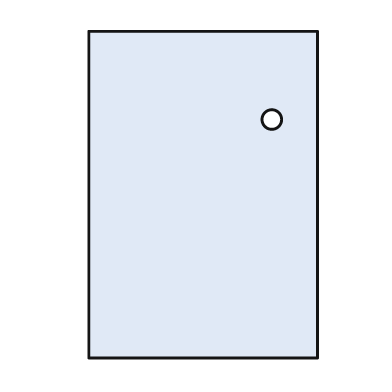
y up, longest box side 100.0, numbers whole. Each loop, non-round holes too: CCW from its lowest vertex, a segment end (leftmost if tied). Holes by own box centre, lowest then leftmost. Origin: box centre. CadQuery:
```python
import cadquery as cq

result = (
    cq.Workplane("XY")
    .moveTo(-35.0, -50.0)
    .lineTo(35.0, -50.0)
    .lineTo(35.0, 50.0)
    .lineTo(-35.0, 50.0)
    .close()
    .moveTo(21.0, 23.0)
    .circle(3.0)
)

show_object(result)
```